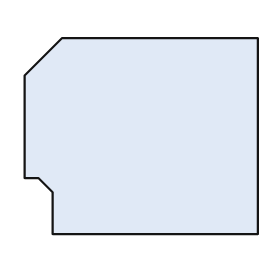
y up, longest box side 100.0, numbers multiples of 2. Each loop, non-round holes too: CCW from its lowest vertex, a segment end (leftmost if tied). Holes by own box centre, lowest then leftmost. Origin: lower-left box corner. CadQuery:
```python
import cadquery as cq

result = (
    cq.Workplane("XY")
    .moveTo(12.0, 0.0)
    .lineTo(100.0, 0.0)
    .lineTo(100.0, 84.0)
    .lineTo(16.0, 84.0)
    .lineTo(0.0, 68.0)
    .lineTo(0.0, 24.0)
    .lineTo(6.0, 24.0)
    .lineTo(12.0, 18.0)
    .close()
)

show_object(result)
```